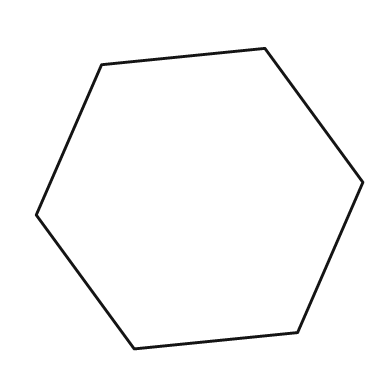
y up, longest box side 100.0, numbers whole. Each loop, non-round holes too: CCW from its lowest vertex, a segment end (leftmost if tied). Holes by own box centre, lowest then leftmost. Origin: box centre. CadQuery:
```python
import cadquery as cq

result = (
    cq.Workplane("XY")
    .moveTo(-20.0, -46.0)
    .lineTo(30.0, -41.0)
    .lineTo(50.0, 5.0)
    .lineTo(20.0, 46.0)
    .lineTo(-30.0, 41.0)
    .lineTo(-50.0, -5.0)
    .close()
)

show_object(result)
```